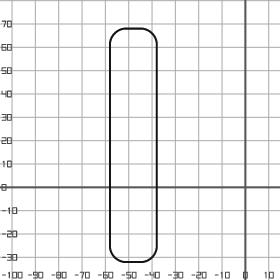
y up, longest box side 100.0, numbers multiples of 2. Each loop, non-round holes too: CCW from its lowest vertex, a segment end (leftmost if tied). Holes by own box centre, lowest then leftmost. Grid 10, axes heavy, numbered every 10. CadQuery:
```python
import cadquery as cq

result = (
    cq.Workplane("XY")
    .moveTo(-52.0, -32.0)
    .lineTo(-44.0, -32.0)
    .threePointArc((-40.0, -30.0), (-38.0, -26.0))
    .lineTo(-38.0, 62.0)
    .threePointArc((-40.0, 66.0), (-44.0, 68.0))
    .lineTo(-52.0, 68.0)
    .threePointArc((-56.0, 66.0), (-58.0, 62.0))
    .lineTo(-58.0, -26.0)
    .threePointArc((-56.0, -30.0), (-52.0, -32.0))
    .close()
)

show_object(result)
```